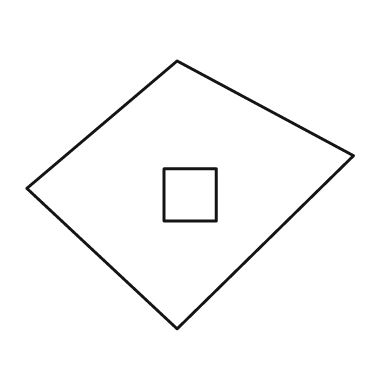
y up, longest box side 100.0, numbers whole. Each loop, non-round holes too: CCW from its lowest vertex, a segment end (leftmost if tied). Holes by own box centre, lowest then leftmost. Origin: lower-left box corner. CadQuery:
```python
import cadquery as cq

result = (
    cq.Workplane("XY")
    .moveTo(46.0, 0.0)
    .lineTo(100.0, 53.0)
    .lineTo(46.0, 82.0)
    .lineTo(0.0, 43.0)
    .close()
    .moveTo(42.0, 33.0)
    .lineTo(58.0, 33.0)
    .lineTo(58.0, 49.0)
    .lineTo(42.0, 49.0)
    .close()
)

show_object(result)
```